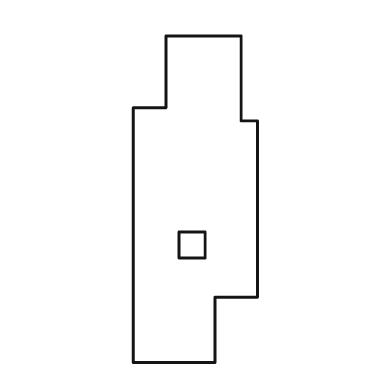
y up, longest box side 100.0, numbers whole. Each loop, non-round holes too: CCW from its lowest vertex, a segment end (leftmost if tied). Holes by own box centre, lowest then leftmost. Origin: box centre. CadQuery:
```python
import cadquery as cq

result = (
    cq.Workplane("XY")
    .moveTo(-19.0, -50.0)
    .lineTo(6.0, -50.0)
    .lineTo(6.0, -30.0)
    .lineTo(19.0, -30.0)
    .lineTo(19.0, 24.0)
    .lineTo(14.0, 24.0)
    .lineTo(14.0, 50.0)
    .lineTo(-9.0, 50.0)
    .lineTo(-9.0, 28.0)
    .lineTo(-19.0, 28.0)
    .close()
    .moveTo(-5.0, -18.0)
    .lineTo(3.0, -18.0)
    .lineTo(3.0, -10.0)
    .lineTo(-5.0, -10.0)
    .close()
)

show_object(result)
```